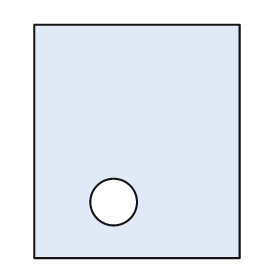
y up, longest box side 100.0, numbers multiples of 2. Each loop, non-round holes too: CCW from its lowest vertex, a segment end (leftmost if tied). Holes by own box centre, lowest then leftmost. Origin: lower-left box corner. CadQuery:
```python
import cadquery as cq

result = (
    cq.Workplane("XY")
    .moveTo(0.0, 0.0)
    .lineTo(88.0, 0.0)
    .lineTo(88.0, 100.0)
    .lineTo(0.0, 100.0)
    .close()
    .moveTo(34.0, 24.0)
    .circle(10.0)
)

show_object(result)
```